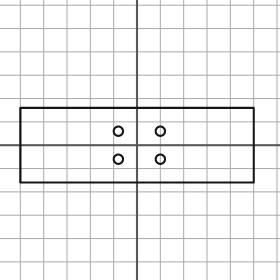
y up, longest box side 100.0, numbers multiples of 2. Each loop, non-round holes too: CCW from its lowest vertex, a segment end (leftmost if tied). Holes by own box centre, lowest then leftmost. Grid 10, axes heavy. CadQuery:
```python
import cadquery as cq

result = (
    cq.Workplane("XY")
    .moveTo(-50.0, -16.0)
    .lineTo(50.0, -16.0)
    .lineTo(50.0, 16.0)
    .lineTo(-50.0, 16.0)
    .close()
    .moveTo(-8.0, -6.0)
    .circle(2.0)
    .moveTo(10.0, -6.0)
    .circle(2.0)
    .moveTo(-8.0, 6.0)
    .circle(2.0)
    .moveTo(10.0, 6.0)
    .circle(2.0)
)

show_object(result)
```